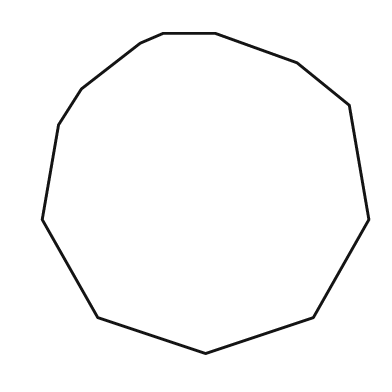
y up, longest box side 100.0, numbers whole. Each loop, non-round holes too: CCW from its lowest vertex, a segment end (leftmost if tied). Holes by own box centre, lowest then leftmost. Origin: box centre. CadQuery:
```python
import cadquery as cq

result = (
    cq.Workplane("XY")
    .moveTo(0.0, -49.0)
    .lineTo(33.0, -38.0)
    .lineTo(50.0, -8.0)
    .lineTo(44.0, 27.0)
    .lineTo(28.0, 40.0)
    .lineTo(3.0, 49.0)
    .lineTo(-13.0, 49.0)
    .lineTo(-20.0, 46.0)
    .lineTo(-38.0, 32.0)
    .lineTo(-45.0, 21.0)
    .lineTo(-50.0, -8.0)
    .lineTo(-33.0, -38.0)
    .close()
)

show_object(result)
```